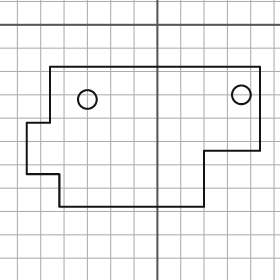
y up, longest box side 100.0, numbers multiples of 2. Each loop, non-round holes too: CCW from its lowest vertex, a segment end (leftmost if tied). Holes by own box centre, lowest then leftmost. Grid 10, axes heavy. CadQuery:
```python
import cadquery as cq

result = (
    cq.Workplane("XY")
    .moveTo(-42.0, -78.0)
    .lineTo(20.0, -78.0)
    .lineTo(20.0, -54.0)
    .lineTo(44.0, -54.0)
    .lineTo(44.0, -18.0)
    .lineTo(-46.0, -18.0)
    .lineTo(-46.0, -42.0)
    .lineTo(-56.0, -42.0)
    .lineTo(-56.0, -64.0)
    .lineTo(-42.0, -64.0)
    .close()
    .moveTo(-30.0, -32.0)
    .circle(4.0)
    .moveTo(36.0, -30.0)
    .circle(4.0)
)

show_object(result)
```